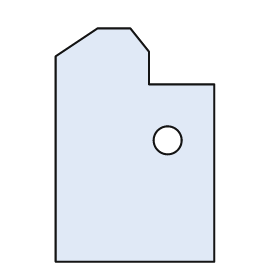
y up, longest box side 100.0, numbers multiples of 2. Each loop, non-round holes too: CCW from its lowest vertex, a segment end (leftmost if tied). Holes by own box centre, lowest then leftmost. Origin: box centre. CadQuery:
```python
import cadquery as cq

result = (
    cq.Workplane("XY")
    .moveTo(-34.0, -50.0)
    .lineTo(34.0, -50.0)
    .lineTo(34.0, 26.0)
    .lineTo(6.0, 26.0)
    .lineTo(6.0, 40.0)
    .lineTo(-2.0, 50.0)
    .lineTo(-16.0, 50.0)
    .lineTo(-34.0, 38.0)
    .close()
    .moveTo(14.0, 2.0)
    .circle(6.0)
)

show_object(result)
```